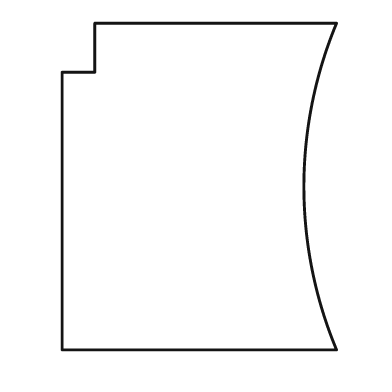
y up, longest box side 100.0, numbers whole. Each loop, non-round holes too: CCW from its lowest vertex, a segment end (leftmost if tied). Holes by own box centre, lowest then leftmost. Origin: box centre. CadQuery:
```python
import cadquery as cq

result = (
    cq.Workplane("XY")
    .moveTo(-42.0, -50.0)
    .lineTo(42.0, -50.0)
    .threePointArc((32.0, 0.0), (42.0, 50.0))
    .lineTo(-32.0, 50.0)
    .lineTo(-32.0, 35.0)
    .lineTo(-42.0, 35.0)
    .close()
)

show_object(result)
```